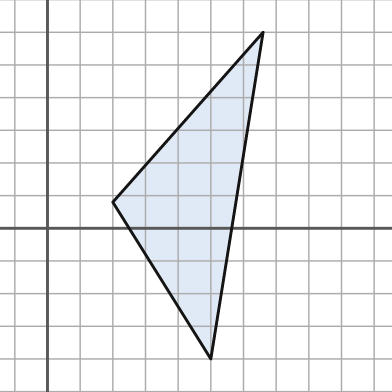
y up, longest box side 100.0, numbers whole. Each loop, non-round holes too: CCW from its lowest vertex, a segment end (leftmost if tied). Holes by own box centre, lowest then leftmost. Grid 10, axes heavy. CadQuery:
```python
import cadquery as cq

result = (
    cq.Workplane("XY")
    .moveTo(50.0, -40.0)
    .lineTo(66.0, 60.0)
    .lineTo(20.0, 8.0)
    .close()
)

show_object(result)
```